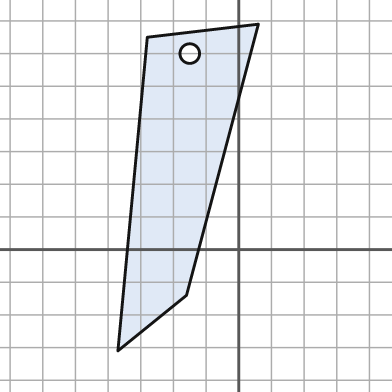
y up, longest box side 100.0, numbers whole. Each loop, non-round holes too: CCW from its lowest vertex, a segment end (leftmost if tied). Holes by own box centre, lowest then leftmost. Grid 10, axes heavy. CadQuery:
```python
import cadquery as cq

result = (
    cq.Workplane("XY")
    .moveTo(-37.0, -31.0)
    .lineTo(-16.0, -14.0)
    .lineTo(6.0, 69.0)
    .lineTo(-28.0, 65.0)
    .close()
    .moveTo(-15.0, 60.0)
    .circle(3.0)
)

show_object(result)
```